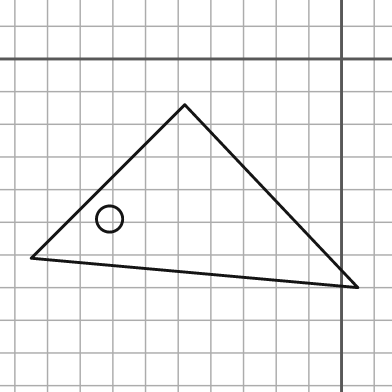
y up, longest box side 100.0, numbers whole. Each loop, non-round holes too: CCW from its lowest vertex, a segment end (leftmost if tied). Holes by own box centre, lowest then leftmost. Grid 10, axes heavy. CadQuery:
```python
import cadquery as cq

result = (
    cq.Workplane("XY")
    .moveTo(5.0, -70.0)
    .lineTo(-48.0, -14.0)
    .lineTo(-95.0, -61.0)
    .close()
    .moveTo(-71.0, -49.0)
    .circle(4.0)
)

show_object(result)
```